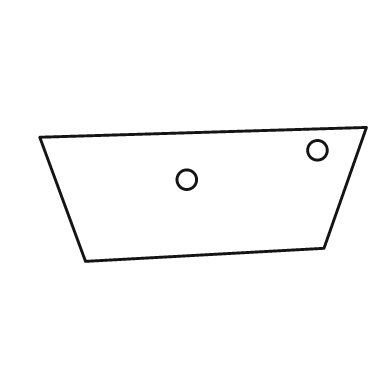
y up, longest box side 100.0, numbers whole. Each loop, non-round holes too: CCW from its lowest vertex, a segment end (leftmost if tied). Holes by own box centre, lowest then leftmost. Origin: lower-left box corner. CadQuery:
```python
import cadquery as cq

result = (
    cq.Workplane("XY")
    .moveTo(14.0, 0.0)
    .lineTo(87.0, 4.0)
    .lineTo(100.0, 41.0)
    .lineTo(0.0, 38.0)
    .close()
    .moveTo(45.0, 25.0)
    .circle(3.0)
    .moveTo(85.0, 34.0)
    .circle(3.0)
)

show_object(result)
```